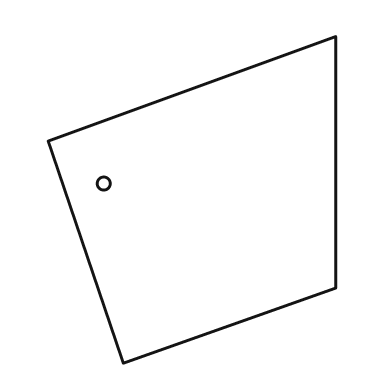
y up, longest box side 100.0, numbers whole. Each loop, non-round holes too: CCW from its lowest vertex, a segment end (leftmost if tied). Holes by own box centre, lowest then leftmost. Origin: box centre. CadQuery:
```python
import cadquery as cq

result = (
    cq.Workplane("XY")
    .moveTo(-21.0, -50.0)
    .lineTo(44.0, -27.0)
    .lineTo(44.0, 50.0)
    .lineTo(-44.0, 18.0)
    .close()
    .moveTo(-27.0, 5.0)
    .circle(2.0)
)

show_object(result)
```